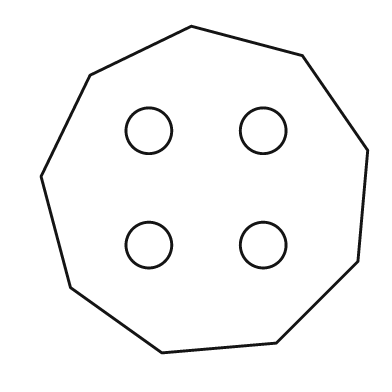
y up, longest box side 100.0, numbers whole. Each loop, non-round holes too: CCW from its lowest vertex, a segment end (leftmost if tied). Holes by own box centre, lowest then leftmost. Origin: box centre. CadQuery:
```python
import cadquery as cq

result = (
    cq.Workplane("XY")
    .moveTo(-13.0, -50.0)
    .lineTo(22.0, -47.0)
    .lineTo(47.0, -22.0)
    .lineTo(50.0, 12.0)
    .lineTo(30.0, 41.0)
    .lineTo(-4.0, 50.0)
    .lineTo(-35.0, 35.0)
    .lineTo(-50.0, 4.0)
    .lineTo(-41.0, -30.0)
    .close()
    .moveTo(-17.0, -17.0)
    .circle(7.0)
    .moveTo(18.0, -17.0)
    .circle(7.0)
    .moveTo(-17.0, 18.0)
    .circle(7.0)
    .moveTo(18.0, 18.0)
    .circle(7.0)
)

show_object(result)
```